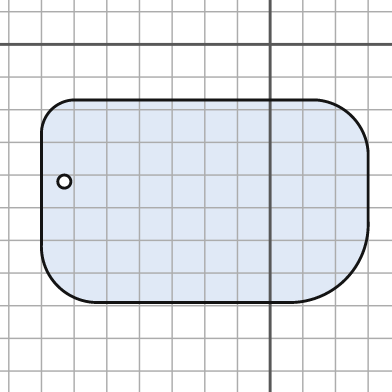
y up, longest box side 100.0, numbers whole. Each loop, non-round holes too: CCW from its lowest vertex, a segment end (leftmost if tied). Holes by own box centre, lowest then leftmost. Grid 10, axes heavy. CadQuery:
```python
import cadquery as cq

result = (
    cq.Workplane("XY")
    .moveTo(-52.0, -79.0)
    .lineTo(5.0, -79.0)
    .threePointArc((23.0, -72.0), (30.0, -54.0))
    .lineTo(30.0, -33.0)
    .threePointArc((25.0, -22.0), (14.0, -17.0))
    .lineTo(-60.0, -17.0)
    .threePointArc((-67.0, -20.0), (-70.0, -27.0))
    .lineTo(-70.0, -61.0)
    .threePointArc((-65.0, -74.0), (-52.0, -79.0))
    .close()
    .moveTo(-63.0, -42.0)
    .circle(2.0)
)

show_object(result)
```